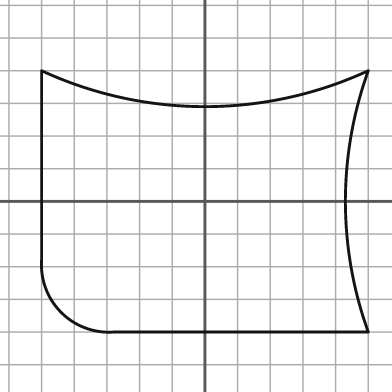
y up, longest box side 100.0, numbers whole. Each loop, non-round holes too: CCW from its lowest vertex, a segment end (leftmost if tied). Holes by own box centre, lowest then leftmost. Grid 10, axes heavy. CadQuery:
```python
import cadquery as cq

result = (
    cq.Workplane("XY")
    .moveTo(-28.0, -40.0)
    .lineTo(50.0, -40.0)
    .threePointArc((43.0, 0.0), (50.0, 40.0))
    .threePointArc((0.0, 29.0), (-50.0, 40.0))
    .lineTo(-50.0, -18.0)
    .threePointArc((-44.0, -34.0), (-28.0, -40.0))
    .close()
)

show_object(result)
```